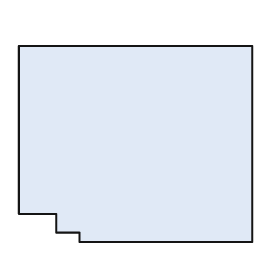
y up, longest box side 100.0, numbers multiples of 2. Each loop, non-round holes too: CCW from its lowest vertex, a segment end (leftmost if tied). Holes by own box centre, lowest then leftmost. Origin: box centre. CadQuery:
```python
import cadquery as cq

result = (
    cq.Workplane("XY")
    .moveTo(-24.0, -42.0)
    .lineTo(50.0, -42.0)
    .lineTo(50.0, 42.0)
    .lineTo(-50.0, 42.0)
    .lineTo(-50.0, -30.0)
    .lineTo(-34.0, -30.0)
    .lineTo(-34.0, -38.0)
    .lineTo(-24.0, -38.0)
    .close()
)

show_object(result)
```